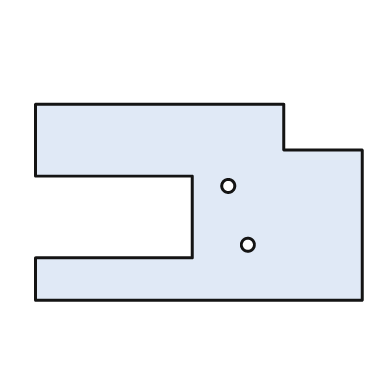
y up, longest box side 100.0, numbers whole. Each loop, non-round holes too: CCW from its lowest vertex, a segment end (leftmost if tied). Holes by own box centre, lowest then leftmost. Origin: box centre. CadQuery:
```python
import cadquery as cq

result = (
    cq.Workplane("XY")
    .moveTo(-50.0, -30.0)
    .lineTo(50.0, -30.0)
    .lineTo(50.0, 16.0)
    .lineTo(26.0, 16.0)
    .lineTo(26.0, 30.0)
    .lineTo(-50.0, 30.0)
    .lineTo(-50.0, 8.0)
    .lineTo(-2.0, 8.0)
    .lineTo(-2.0, -17.0)
    .lineTo(-50.0, -17.0)
    .close()
    .moveTo(15.0, -13.0)
    .circle(2.0)
    .moveTo(9.0, 5.0)
    .circle(2.0)
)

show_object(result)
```